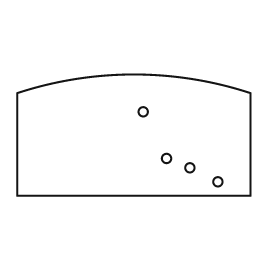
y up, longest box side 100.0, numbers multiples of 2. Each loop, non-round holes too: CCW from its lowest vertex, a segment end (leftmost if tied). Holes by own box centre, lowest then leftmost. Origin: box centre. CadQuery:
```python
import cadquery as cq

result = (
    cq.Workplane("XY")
    .moveTo(-50.0, -26.0)
    .lineTo(50.0, -26.0)
    .lineTo(50.0, 18.0)
    .threePointArc((0.0, 26.0), (-50.0, 18.0))
    .close()
    .moveTo(36.0, -20.0)
    .circle(2.0)
    .moveTo(24.0, -14.0)
    .circle(2.0)
    .moveTo(14.0, -10.0)
    .circle(2.0)
    .moveTo(4.0, 10.0)
    .circle(2.0)
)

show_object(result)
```